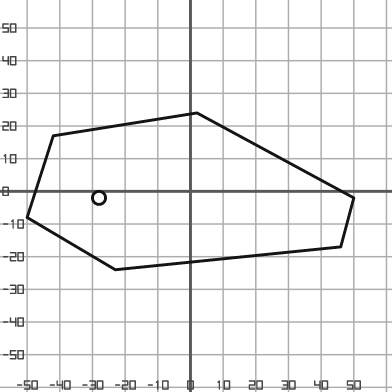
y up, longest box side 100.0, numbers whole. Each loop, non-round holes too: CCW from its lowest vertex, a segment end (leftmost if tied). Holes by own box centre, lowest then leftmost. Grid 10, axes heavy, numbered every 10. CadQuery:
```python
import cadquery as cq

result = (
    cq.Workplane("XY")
    .moveTo(-23.0, -24.0)
    .lineTo(46.0, -17.0)
    .lineTo(50.0, -2.0)
    .lineTo(2.0, 24.0)
    .lineTo(-42.0, 17.0)
    .lineTo(-50.0, -8.0)
    .close()
    .moveTo(-28.0, -2.0)
    .circle(2.0)
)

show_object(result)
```